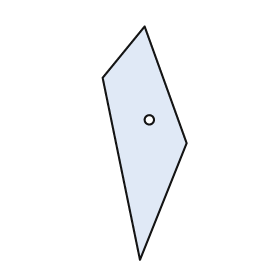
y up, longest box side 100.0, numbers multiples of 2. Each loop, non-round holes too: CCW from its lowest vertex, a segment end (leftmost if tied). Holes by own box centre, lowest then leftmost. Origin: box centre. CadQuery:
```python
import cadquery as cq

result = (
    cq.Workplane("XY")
    .moveTo(-2.0, -50.0)
    .lineTo(18.0, 0.0)
    .lineTo(0.0, 50.0)
    .lineTo(-18.0, 28.0)
    .close()
    .moveTo(2.0, 10.0)
    .circle(2.0)
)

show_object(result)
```